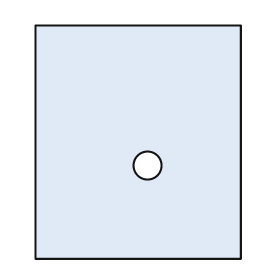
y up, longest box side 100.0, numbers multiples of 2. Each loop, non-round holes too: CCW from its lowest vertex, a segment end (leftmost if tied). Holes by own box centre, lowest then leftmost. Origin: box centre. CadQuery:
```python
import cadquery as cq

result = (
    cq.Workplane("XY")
    .moveTo(-44.0, -50.0)
    .lineTo(44.0, -50.0)
    .lineTo(44.0, 50.0)
    .lineTo(-44.0, 50.0)
    .close()
    .moveTo(4.0, -10.0)
    .circle(6.0)
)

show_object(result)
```